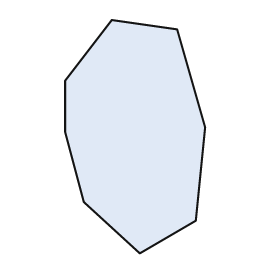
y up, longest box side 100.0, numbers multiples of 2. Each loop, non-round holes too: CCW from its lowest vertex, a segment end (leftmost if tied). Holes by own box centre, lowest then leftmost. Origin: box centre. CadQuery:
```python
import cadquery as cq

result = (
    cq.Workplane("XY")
    .moveTo(2.0, -50.0)
    .lineTo(26.0, -36.0)
    .lineTo(30.0, 4.0)
    .lineTo(18.0, 46.0)
    .lineTo(-10.0, 50.0)
    .lineTo(-30.0, 24.0)
    .lineTo(-30.0, 2.0)
    .lineTo(-22.0, -28.0)
    .close()
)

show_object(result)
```